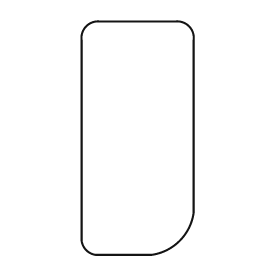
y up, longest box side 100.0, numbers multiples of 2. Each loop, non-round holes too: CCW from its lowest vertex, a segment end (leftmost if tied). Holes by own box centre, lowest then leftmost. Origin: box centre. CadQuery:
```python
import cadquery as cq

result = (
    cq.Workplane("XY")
    .moveTo(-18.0, -50.0)
    .lineTo(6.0, -50.0)
    .threePointArc((18.0, -44.0), (24.0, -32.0))
    .lineTo(24.0, 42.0)
    .threePointArc((22.0, 48.0), (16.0, 50.0))
    .lineTo(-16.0, 50.0)
    .threePointArc((-22.0, 48.0), (-24.0, 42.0))
    .lineTo(-24.0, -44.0)
    .threePointArc((-22.0, -48.0), (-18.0, -50.0))
    .close()
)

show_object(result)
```